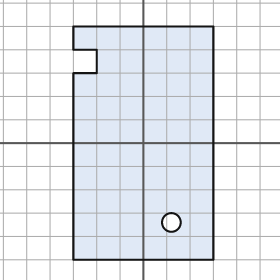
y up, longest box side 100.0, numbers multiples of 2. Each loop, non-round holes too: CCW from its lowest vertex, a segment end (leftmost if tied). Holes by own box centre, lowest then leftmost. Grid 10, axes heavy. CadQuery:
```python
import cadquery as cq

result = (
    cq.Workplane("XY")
    .moveTo(-30.0, -50.0)
    .lineTo(30.0, -50.0)
    .lineTo(30.0, 50.0)
    .lineTo(-30.0, 50.0)
    .lineTo(-30.0, 40.0)
    .lineTo(-20.0, 40.0)
    .lineTo(-20.0, 30.0)
    .lineTo(-30.0, 30.0)
    .close()
    .moveTo(12.0, -34.0)
    .circle(4.0)
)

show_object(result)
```